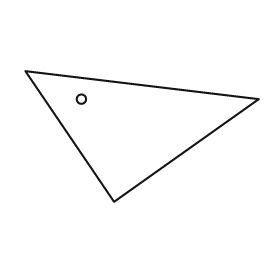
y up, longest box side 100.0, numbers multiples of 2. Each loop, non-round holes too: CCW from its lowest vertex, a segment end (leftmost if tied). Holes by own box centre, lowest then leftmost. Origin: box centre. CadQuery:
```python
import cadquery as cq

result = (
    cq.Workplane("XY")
    .moveTo(-12.0, -28.0)
    .lineTo(50.0, 16.0)
    .lineTo(-50.0, 28.0)
    .close()
    .moveTo(-26.0, 16.0)
    .circle(2.0)
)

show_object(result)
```